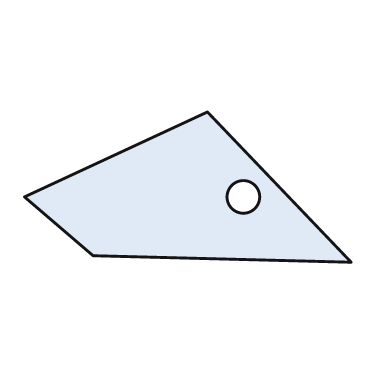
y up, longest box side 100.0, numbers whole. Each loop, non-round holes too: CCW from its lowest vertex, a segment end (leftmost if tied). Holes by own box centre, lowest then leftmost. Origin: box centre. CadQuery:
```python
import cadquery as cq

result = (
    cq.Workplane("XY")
    .moveTo(50.0, -23.0)
    .lineTo(6.0, 23.0)
    .lineTo(-50.0, -3.0)
    .lineTo(-29.0, -21.0)
    .close()
    .moveTo(17.0, -3.0)
    .circle(5.0)
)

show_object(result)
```